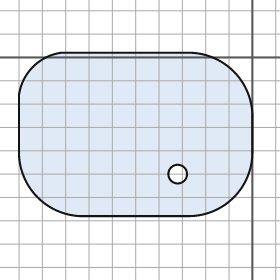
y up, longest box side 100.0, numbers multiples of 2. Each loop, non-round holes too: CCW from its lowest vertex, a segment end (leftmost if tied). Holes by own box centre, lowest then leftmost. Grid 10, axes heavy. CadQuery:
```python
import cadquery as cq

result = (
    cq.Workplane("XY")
    .moveTo(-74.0, -68.0)
    .lineTo(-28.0, -68.0)
    .threePointArc((-8.0, -60.0), (0.0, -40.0))
    .lineTo(0.0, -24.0)
    .threePointArc((-8.0, -6.0), (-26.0, 2.0))
    .lineTo(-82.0, 2.0)
    .threePointArc((-94.0, -4.0), (-100.0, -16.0))
    .lineTo(-100.0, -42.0)
    .threePointArc((-92.0, -60.0), (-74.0, -68.0))
    .close()
    .moveTo(-32.0, -50.0)
    .circle(4.0)
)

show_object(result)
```